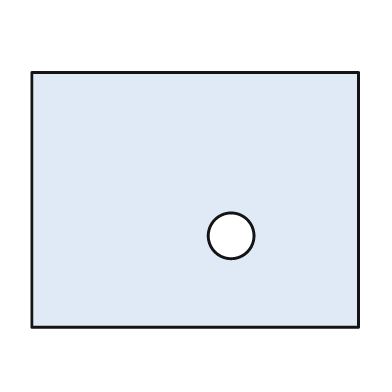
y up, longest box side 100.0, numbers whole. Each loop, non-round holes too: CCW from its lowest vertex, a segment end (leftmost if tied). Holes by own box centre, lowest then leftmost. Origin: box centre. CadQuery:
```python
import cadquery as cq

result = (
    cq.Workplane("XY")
    .moveTo(-50.0, -39.0)
    .lineTo(50.0, -39.0)
    .lineTo(50.0, 39.0)
    .lineTo(-50.0, 39.0)
    .close()
    .moveTo(11.0, -11.0)
    .circle(7.0)
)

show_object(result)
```